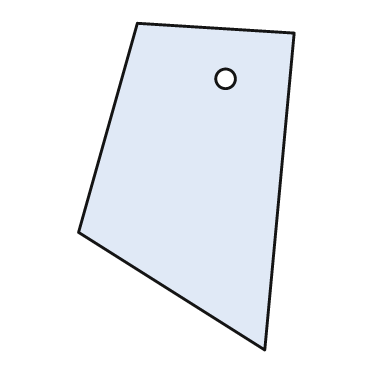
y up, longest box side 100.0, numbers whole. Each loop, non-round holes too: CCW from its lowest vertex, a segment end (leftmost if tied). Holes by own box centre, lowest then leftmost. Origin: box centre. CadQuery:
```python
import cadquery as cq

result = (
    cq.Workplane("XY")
    .moveTo(24.0, -50.0)
    .lineTo(33.0, 47.0)
    .lineTo(-15.0, 50.0)
    .lineTo(-33.0, -14.0)
    .close()
    .moveTo(12.0, 33.0)
    .circle(3.0)
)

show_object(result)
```